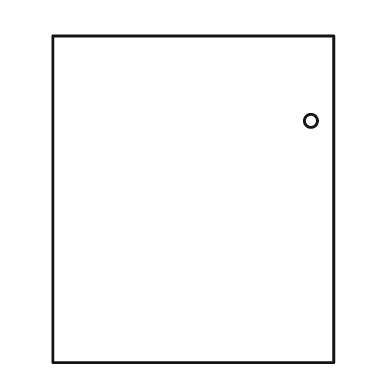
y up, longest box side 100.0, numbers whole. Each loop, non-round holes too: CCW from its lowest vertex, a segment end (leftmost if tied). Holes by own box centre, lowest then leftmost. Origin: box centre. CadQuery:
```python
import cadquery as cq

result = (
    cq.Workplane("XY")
    .moveTo(-43.0, -50.0)
    .lineTo(43.0, -50.0)
    .lineTo(43.0, 50.0)
    .lineTo(-43.0, 50.0)
    .close()
    .moveTo(36.0, 24.0)
    .circle(2.0)
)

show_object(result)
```